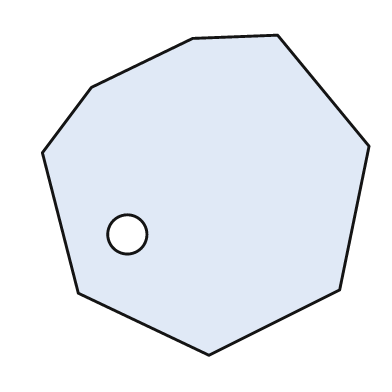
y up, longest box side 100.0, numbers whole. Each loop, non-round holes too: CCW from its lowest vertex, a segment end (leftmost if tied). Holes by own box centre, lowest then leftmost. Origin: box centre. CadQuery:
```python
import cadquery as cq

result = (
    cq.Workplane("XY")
    .moveTo(1.0, -49.0)
    .lineTo(41.0, -29.0)
    .lineTo(50.0, 15.0)
    .lineTo(22.0, 49.0)
    .lineTo(-4.0, 48.0)
    .lineTo(-35.0, 33.0)
    .lineTo(-50.0, 13.0)
    .lineTo(-39.0, -30.0)
    .close()
    .moveTo(-24.0, -12.0)
    .circle(6.0)
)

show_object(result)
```